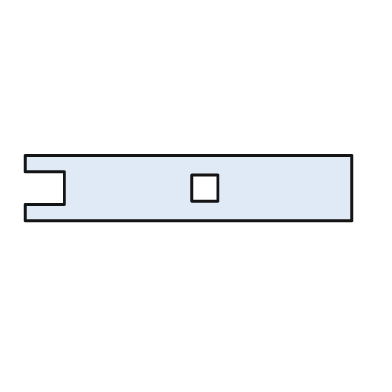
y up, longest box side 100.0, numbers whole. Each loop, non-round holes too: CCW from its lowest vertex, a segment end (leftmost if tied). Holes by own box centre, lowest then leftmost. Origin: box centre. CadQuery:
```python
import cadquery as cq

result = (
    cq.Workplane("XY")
    .moveTo(-50.0, -10.0)
    .lineTo(50.0, -10.0)
    .lineTo(50.0, 10.0)
    .lineTo(-50.0, 10.0)
    .lineTo(-50.0, 5.0)
    .lineTo(-38.0, 5.0)
    .lineTo(-38.0, -5.0)
    .lineTo(-50.0, -5.0)
    .close()
    .moveTo(1.0, -4.0)
    .lineTo(9.0, -4.0)
    .lineTo(9.0, 4.0)
    .lineTo(1.0, 4.0)
    .close()
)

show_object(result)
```